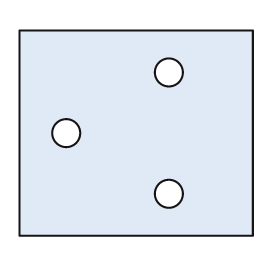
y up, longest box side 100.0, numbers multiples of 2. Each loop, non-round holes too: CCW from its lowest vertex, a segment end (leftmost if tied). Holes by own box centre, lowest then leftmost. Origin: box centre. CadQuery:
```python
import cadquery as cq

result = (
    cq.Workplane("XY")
    .moveTo(-50.0, -44.0)
    .lineTo(50.0, -44.0)
    .lineTo(50.0, 44.0)
    .lineTo(-50.0, 44.0)
    .close()
    .moveTo(14.0, -26.0)
    .circle(6.0)
    .moveTo(-30.0, 0.0)
    .circle(6.0)
    .moveTo(14.0, 26.0)
    .circle(6.0)
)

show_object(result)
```